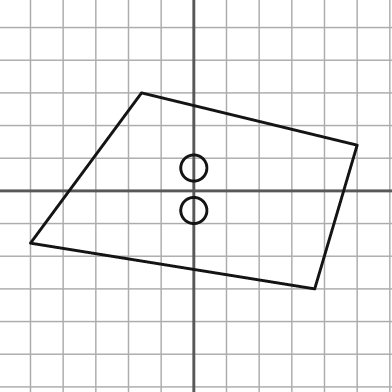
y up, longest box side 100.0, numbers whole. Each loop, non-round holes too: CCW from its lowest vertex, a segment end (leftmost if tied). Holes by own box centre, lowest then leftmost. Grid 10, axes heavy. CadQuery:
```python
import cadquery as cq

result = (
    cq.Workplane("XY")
    .moveTo(37.0, -30.0)
    .lineTo(50.0, 14.0)
    .lineTo(-16.0, 30.0)
    .lineTo(-50.0, -16.0)
    .close()
    .moveTo(0.0, -6.0)
    .circle(4.0)
    .moveTo(0.0, 7.0)
    .circle(4.0)
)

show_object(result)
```